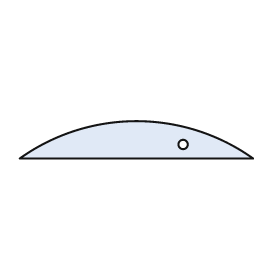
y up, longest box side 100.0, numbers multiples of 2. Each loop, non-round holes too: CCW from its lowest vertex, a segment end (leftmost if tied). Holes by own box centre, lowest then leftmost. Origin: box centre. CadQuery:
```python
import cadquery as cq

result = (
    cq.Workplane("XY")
    .moveTo(-50.0, -8.0)
    .lineTo(50.0, -8.0)
    .threePointArc((0.0, 8.0), (-50.0, -8.0))
    .close()
    .moveTo(20.0, -2.0)
    .circle(2.0)
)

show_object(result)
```